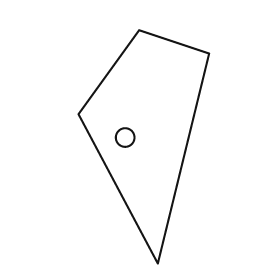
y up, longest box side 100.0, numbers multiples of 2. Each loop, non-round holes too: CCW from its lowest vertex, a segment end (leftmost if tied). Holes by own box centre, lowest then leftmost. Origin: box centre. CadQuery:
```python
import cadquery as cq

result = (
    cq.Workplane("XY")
    .moveTo(6.0, -50.0)
    .lineTo(28.0, 40.0)
    .lineTo(-2.0, 50.0)
    .lineTo(-28.0, 14.0)
    .close()
    .moveTo(-8.0, 4.0)
    .circle(4.0)
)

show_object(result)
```